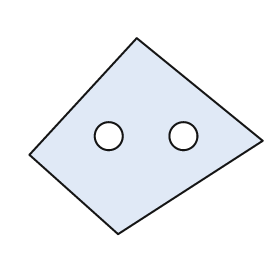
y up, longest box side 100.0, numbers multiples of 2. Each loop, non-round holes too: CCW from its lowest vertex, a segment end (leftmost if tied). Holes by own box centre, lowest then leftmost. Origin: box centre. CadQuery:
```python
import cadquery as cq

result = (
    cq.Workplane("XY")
    .moveTo(-12.0, -42.0)
    .lineTo(50.0, -2.0)
    .lineTo(-4.0, 42.0)
    .lineTo(-50.0, -8.0)
    .close()
    .moveTo(-16.0, 0.0)
    .circle(6.0)
    .moveTo(16.0, 0.0)
    .circle(6.0)
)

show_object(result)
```